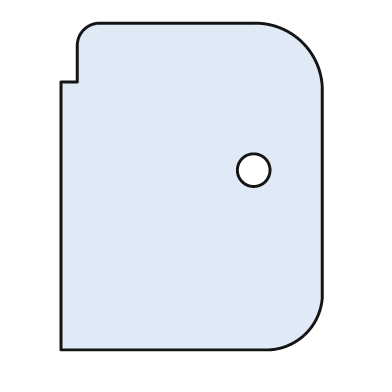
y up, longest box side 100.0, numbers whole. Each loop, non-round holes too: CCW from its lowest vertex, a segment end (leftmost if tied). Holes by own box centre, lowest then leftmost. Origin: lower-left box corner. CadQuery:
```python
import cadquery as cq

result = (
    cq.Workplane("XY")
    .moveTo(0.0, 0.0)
    .lineTo(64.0, 0.0)
    .threePointArc((75.0, 5.0), (80.0, 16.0))
    .lineTo(80.0, 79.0)
    .threePointArc((74.0, 94.0), (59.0, 100.0))
    .lineTo(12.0, 100.0)
    .threePointArc((7.0, 98.0), (5.0, 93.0))
    .lineTo(5.0, 82.0)
    .lineTo(0.0, 82.0)
    .close()
    .moveTo(59.0, 55.0)
    .circle(5.0)
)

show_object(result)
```